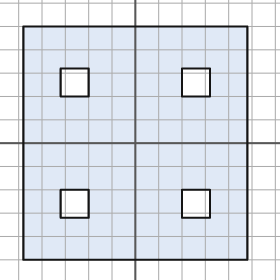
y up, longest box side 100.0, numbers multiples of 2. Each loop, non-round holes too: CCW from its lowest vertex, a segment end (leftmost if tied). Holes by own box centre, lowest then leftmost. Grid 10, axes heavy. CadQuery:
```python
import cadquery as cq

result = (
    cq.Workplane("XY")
    .moveTo(-48.0, -50.0)
    .lineTo(48.0, -50.0)
    .lineTo(48.0, 50.0)
    .lineTo(-48.0, 50.0)
    .close()
    .moveTo(-32.0, -32.0)
    .lineTo(-20.0, -32.0)
    .lineTo(-20.0, -20.0)
    .lineTo(-32.0, -20.0)
    .close()
    .moveTo(20.0, -32.0)
    .lineTo(32.0, -32.0)
    .lineTo(32.0, -20.0)
    .lineTo(20.0, -20.0)
    .close()
    .moveTo(-32.0, 20.0)
    .lineTo(-20.0, 20.0)
    .lineTo(-20.0, 32.0)
    .lineTo(-32.0, 32.0)
    .close()
    .moveTo(20.0, 20.0)
    .lineTo(32.0, 20.0)
    .lineTo(32.0, 32.0)
    .lineTo(20.0, 32.0)
    .close()
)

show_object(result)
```